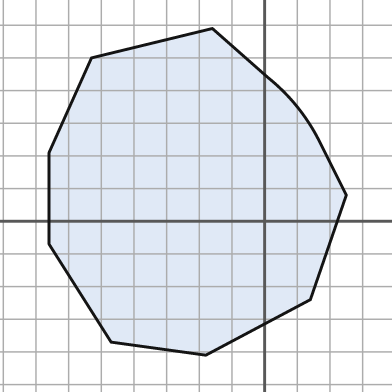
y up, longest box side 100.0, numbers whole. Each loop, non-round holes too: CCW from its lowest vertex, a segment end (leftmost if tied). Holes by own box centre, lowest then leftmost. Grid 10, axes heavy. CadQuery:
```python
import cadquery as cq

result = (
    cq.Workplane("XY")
    .moveTo(-18.0, -41.0)
    .lineTo(14.0, -24.0)
    .lineTo(25.0, 8.0)
    .lineTo(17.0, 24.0)
    .threePointArc((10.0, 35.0), (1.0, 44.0))
    .lineTo(-16.0, 59.0)
    .lineTo(-53.0, 50.0)
    .lineTo(-66.0, 21.0)
    .lineTo(-66.0, -7.0)
    .lineTo(-47.0, -37.0)
    .close()
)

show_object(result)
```